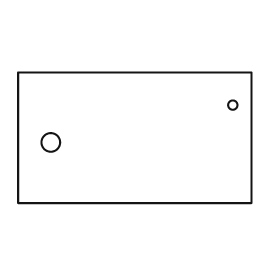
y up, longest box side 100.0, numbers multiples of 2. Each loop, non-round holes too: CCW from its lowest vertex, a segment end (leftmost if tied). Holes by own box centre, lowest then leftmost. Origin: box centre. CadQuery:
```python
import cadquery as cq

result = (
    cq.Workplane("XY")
    .moveTo(-50.0, -28.0)
    .lineTo(50.0, -28.0)
    .lineTo(50.0, 28.0)
    .lineTo(-50.0, 28.0)
    .close()
    .moveTo(-36.0, -2.0)
    .circle(4.0)
    .moveTo(42.0, 14.0)
    .circle(2.0)
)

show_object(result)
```